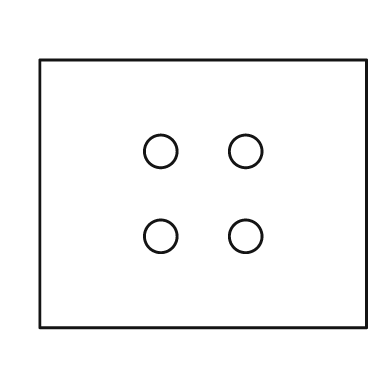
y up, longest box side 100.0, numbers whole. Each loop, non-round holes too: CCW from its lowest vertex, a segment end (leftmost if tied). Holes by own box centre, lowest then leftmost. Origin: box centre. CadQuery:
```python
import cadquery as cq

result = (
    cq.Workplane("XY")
    .moveTo(-50.0, -41.0)
    .lineTo(50.0, -41.0)
    .lineTo(50.0, 41.0)
    .lineTo(-50.0, 41.0)
    .close()
    .moveTo(-13.0, -13.0)
    .circle(5.0)
    .moveTo(13.0, -13.0)
    .circle(5.0)
    .moveTo(-13.0, 13.0)
    .circle(5.0)
    .moveTo(13.0, 13.0)
    .circle(5.0)
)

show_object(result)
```